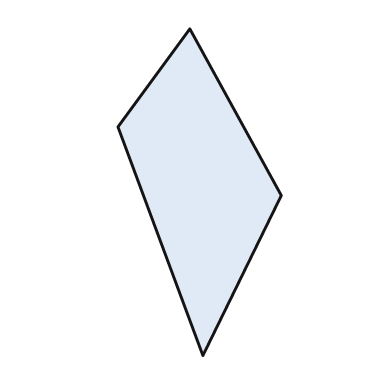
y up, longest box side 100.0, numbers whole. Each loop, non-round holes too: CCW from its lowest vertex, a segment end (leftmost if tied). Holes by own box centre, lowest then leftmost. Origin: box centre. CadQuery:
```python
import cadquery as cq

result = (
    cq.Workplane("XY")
    .moveTo(1.0, -50.0)
    .lineTo(25.0, -1.0)
    .lineTo(-3.0, 50.0)
    .lineTo(-25.0, 20.0)
    .close()
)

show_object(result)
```